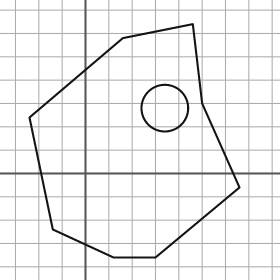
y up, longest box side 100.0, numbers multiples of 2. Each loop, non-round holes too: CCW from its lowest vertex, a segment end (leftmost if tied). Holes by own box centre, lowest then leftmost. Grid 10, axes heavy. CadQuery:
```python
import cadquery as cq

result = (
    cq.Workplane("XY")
    .moveTo(12.0, -36.0)
    .lineTo(30.0, -36.0)
    .lineTo(66.0, -6.0)
    .lineTo(50.0, 30.0)
    .lineTo(46.0, 64.0)
    .lineTo(16.0, 58.0)
    .lineTo(-24.0, 24.0)
    .lineTo(-14.0, -24.0)
    .close()
    .moveTo(34.0, 28.0)
    .circle(10.0)
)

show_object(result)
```